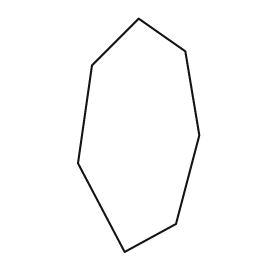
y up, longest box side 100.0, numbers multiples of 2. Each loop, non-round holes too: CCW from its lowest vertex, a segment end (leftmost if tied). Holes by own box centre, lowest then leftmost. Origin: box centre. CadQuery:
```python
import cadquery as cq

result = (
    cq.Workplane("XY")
    .moveTo(-6.0, -50.0)
    .lineTo(16.0, -38.0)
    .lineTo(26.0, 0.0)
    .lineTo(20.0, 36.0)
    .lineTo(0.0, 50.0)
    .lineTo(-20.0, 30.0)
    .lineTo(-26.0, -12.0)
    .close()
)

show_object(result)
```